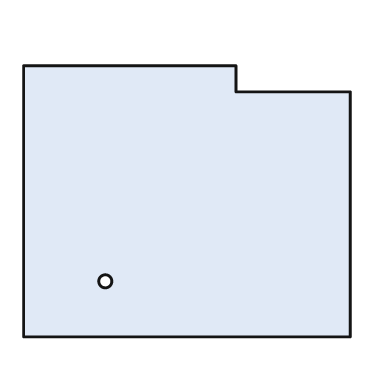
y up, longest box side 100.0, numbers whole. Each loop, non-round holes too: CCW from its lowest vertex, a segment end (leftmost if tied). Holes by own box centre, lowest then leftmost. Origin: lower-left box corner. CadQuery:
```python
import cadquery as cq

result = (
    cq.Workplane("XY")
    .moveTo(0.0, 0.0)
    .lineTo(100.0, 0.0)
    .lineTo(100.0, 75.0)
    .lineTo(65.0, 75.0)
    .lineTo(65.0, 83.0)
    .lineTo(0.0, 83.0)
    .close()
    .moveTo(25.0, 17.0)
    .circle(2.0)
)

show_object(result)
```